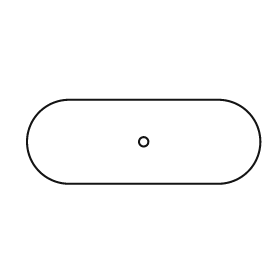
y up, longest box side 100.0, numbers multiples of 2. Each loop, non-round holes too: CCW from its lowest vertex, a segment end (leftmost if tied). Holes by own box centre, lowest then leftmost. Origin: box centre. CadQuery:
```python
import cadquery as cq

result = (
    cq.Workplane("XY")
    .moveTo(-32.0, -18.0)
    .lineTo(32.0, -18.0)
    .threePointArc((50.0, 0.0), (32.0, 18.0))
    .lineTo(-32.0, 18.0)
    .threePointArc((-50.0, 0.0), (-32.0, -18.0))
    .close()
    .moveTo(0.0, 0.0)
    .circle(2.0)
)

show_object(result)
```